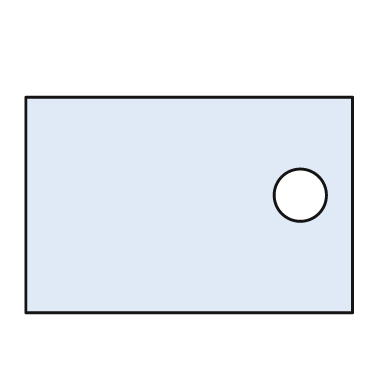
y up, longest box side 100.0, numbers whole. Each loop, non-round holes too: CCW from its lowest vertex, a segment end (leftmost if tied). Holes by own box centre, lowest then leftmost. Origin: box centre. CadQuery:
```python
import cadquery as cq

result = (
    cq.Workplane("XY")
    .moveTo(-50.0, -33.0)
    .lineTo(50.0, -33.0)
    .lineTo(50.0, 33.0)
    .lineTo(-50.0, 33.0)
    .close()
    .moveTo(34.0, 3.0)
    .circle(8.0)
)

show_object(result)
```